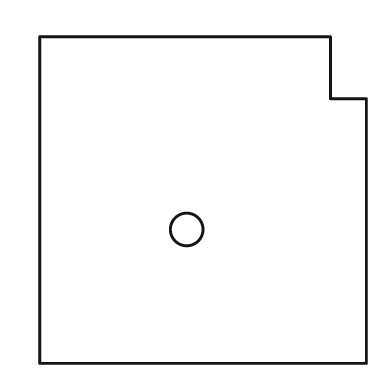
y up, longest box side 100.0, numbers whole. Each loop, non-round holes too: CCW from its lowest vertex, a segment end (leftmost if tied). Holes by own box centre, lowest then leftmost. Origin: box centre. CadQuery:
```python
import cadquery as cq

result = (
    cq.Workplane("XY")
    .moveTo(-50.0, -50.0)
    .lineTo(50.0, -50.0)
    .lineTo(50.0, 31.0)
    .lineTo(39.0, 31.0)
    .lineTo(39.0, 50.0)
    .lineTo(-50.0, 50.0)
    .close()
    .moveTo(-5.0, -9.0)
    .circle(5.0)
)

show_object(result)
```